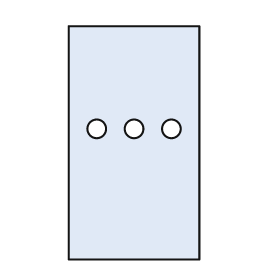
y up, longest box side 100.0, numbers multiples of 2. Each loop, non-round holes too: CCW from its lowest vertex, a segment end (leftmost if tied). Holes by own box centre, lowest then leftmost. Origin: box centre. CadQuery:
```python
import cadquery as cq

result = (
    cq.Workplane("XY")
    .moveTo(-28.0, -50.0)
    .lineTo(28.0, -50.0)
    .lineTo(28.0, 50.0)
    .lineTo(-28.0, 50.0)
    .close()
    .moveTo(-16.0, 6.0)
    .circle(4.0)
    .moveTo(0.0, 6.0)
    .circle(4.0)
    .moveTo(16.0, 6.0)
    .circle(4.0)
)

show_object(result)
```